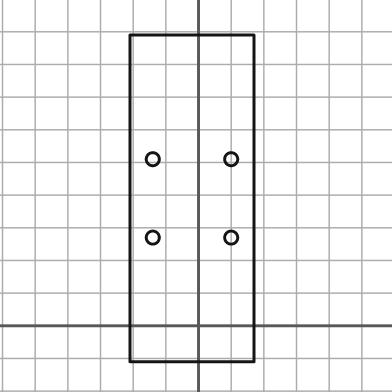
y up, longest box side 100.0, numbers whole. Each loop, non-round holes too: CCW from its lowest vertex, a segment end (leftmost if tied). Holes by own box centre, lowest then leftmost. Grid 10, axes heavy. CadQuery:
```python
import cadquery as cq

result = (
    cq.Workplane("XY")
    .moveTo(-21.0, -11.0)
    .lineTo(17.0, -11.0)
    .lineTo(17.0, 89.0)
    .lineTo(-21.0, 89.0)
    .close()
    .moveTo(-14.0, 27.0)
    .circle(2.0)
    .moveTo(10.0, 27.0)
    .circle(2.0)
    .moveTo(-14.0, 51.0)
    .circle(2.0)
    .moveTo(10.0, 51.0)
    .circle(2.0)
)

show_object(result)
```